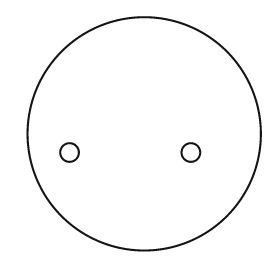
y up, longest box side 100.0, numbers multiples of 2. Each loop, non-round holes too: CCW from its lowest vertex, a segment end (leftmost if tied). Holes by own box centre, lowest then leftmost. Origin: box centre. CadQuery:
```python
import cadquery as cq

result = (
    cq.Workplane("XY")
    .moveTo(0.0, 0.0)
    .circle(50.0)
    .moveTo(-32.0, -8.0)
    .circle(4.0)
    .moveTo(20.0, -8.0)
    .circle(4.0)
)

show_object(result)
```